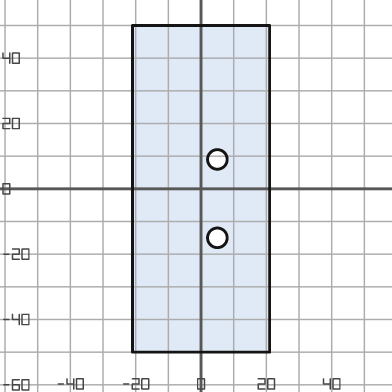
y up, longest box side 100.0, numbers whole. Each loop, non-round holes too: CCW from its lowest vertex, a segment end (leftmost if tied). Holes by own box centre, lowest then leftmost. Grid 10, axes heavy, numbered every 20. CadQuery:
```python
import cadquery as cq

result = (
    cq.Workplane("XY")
    .moveTo(-21.0, -50.0)
    .lineTo(21.0, -50.0)
    .lineTo(21.0, 50.0)
    .lineTo(-21.0, 50.0)
    .close()
    .moveTo(5.0, -15.0)
    .circle(3.0)
    .moveTo(5.0, 9.0)
    .circle(3.0)
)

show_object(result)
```